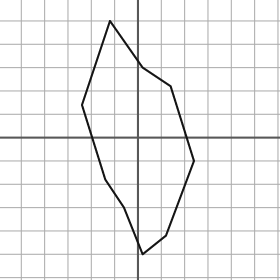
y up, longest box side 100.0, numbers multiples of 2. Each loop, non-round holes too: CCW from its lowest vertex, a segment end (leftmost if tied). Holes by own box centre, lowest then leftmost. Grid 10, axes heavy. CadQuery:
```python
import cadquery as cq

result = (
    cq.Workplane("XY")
    .moveTo(2.0, -50.0)
    .lineTo(12.0, -42.0)
    .lineTo(24.0, -10.0)
    .lineTo(14.0, 22.0)
    .lineTo(2.0, 30.0)
    .lineTo(-12.0, 50.0)
    .lineTo(-24.0, 14.0)
    .lineTo(-14.0, -18.0)
    .lineTo(-6.0, -30.0)
    .close()
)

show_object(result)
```